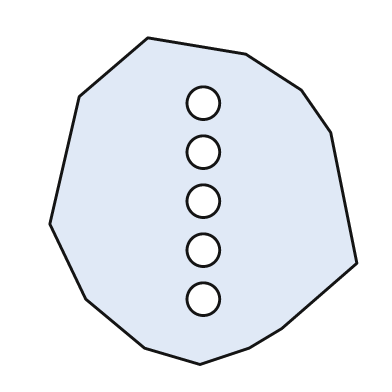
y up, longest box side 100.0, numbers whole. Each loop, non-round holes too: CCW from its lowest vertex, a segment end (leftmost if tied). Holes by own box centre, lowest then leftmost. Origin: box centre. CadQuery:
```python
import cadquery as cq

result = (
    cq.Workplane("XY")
    .moveTo(-1.0, -50.0)
    .lineTo(14.0, -45.0)
    .lineTo(24.0, -39.0)
    .lineTo(47.0, -19.0)
    .lineTo(39.0, 21.0)
    .lineTo(30.0, 34.0)
    .lineTo(13.0, 45.0)
    .lineTo(-17.0, 50.0)
    .lineTo(-38.0, 32.0)
    .lineTo(-47.0, -7.0)
    .lineTo(-36.0, -30.0)
    .lineTo(-18.0, -45.0)
    .close()
    .moveTo(0.0, -30.0)
    .circle(5.0)
    .moveTo(0.0, -15.0)
    .circle(5.0)
    .moveTo(0.0, 0.0)
    .circle(5.0)
    .moveTo(0.0, 15.0)
    .circle(5.0)
    .moveTo(0.0, 30.0)
    .circle(5.0)
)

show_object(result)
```